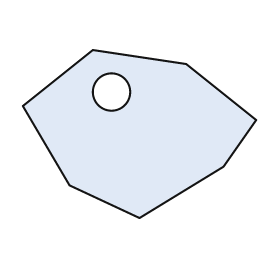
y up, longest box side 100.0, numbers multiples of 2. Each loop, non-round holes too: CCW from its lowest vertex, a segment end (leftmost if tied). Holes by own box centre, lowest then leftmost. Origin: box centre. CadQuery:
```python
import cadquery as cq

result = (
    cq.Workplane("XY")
    .moveTo(0.0, -36.0)
    .lineTo(36.0, -14.0)
    .lineTo(50.0, 6.0)
    .lineTo(20.0, 30.0)
    .lineTo(-20.0, 36.0)
    .lineTo(-50.0, 12.0)
    .lineTo(-30.0, -22.0)
    .close()
    .moveTo(-12.0, 18.0)
    .circle(8.0)
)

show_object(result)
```